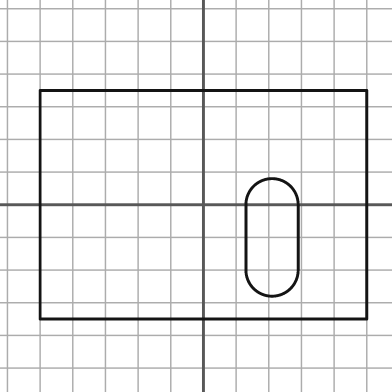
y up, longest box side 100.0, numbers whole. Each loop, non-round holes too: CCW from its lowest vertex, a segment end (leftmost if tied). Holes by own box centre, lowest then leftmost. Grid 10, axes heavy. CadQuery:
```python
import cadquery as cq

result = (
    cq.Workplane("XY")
    .moveTo(-50.0, -35.0)
    .lineTo(50.0, -35.0)
    .lineTo(50.0, 35.0)
    .lineTo(-50.0, 35.0)
    .close()
    .moveTo(13.0, -20.0)
    .threePointArc((21.0, -28.0), (29.0, -20.0))
    .lineTo(29.0, 0.0)
    .threePointArc((21.0, 8.0), (13.0, 0.0))
    .close()
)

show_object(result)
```